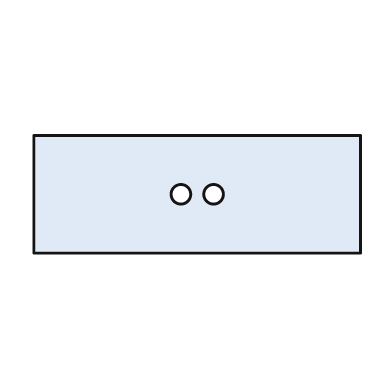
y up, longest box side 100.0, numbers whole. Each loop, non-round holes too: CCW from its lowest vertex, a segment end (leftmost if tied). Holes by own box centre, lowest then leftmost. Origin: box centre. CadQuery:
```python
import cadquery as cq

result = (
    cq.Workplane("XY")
    .moveTo(-50.0, -18.0)
    .lineTo(50.0, -18.0)
    .lineTo(50.0, 18.0)
    .lineTo(-50.0, 18.0)
    .close()
    .moveTo(-5.0, 0.0)
    .circle(3.0)
    .moveTo(5.0, 0.0)
    .circle(3.0)
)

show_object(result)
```